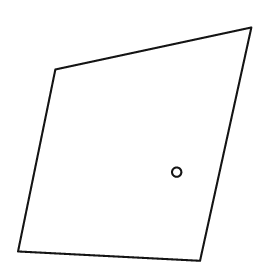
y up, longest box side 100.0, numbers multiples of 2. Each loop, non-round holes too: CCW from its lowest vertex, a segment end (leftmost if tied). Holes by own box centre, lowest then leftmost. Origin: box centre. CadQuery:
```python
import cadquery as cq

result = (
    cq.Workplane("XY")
    .moveTo(28.0, -50.0)
    .lineTo(50.0, 50.0)
    .lineTo(-34.0, 32.0)
    .lineTo(-50.0, -46.0)
    .close()
    .moveTo(18.0, -12.0)
    .circle(2.0)
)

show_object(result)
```